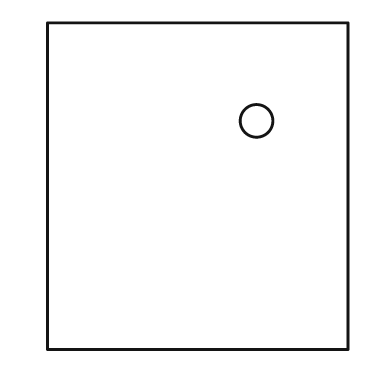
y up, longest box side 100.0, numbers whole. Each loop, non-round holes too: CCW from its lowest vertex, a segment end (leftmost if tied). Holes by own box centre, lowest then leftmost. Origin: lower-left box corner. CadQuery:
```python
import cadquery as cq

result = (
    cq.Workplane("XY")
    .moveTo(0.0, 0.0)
    .lineTo(92.0, 0.0)
    .lineTo(92.0, 100.0)
    .lineTo(0.0, 100.0)
    .close()
    .moveTo(64.0, 70.0)
    .circle(5.0)
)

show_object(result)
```